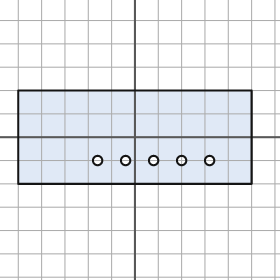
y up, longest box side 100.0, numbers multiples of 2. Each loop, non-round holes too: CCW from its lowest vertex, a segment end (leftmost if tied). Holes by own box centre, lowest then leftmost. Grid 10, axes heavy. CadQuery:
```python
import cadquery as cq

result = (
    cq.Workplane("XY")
    .moveTo(-50.0, -20.0)
    .lineTo(50.0, -20.0)
    .lineTo(50.0, 20.0)
    .lineTo(-50.0, 20.0)
    .close()
    .moveTo(-16.0, -10.0)
    .circle(2.0)
    .moveTo(-4.0, -10.0)
    .circle(2.0)
    .moveTo(8.0, -10.0)
    .circle(2.0)
    .moveTo(20.0, -10.0)
    .circle(2.0)
    .moveTo(32.0, -10.0)
    .circle(2.0)
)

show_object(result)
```